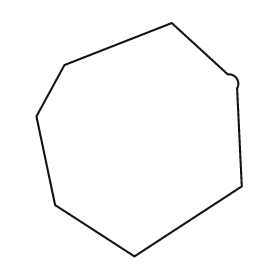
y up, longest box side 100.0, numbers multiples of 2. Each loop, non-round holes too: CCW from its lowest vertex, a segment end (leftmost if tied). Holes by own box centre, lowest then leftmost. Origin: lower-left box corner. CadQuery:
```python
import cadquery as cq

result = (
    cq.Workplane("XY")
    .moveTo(42.0, 0.0)
    .lineTo(88.0, 30.0)
    .lineTo(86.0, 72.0)
    .threePointArc((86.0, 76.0), (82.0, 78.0))
    .lineTo(58.0, 100.0)
    .lineTo(12.0, 82.0)
    .lineTo(0.0, 60.0)
    .lineTo(8.0, 22.0)
    .close()
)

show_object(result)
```